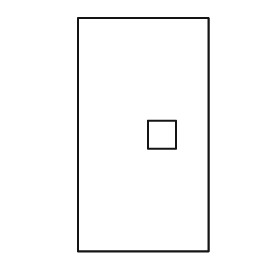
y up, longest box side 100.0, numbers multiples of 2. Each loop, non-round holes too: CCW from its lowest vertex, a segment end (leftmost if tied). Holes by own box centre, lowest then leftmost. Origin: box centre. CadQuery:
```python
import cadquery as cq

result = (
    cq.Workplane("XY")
    .moveTo(-28.0, -50.0)
    .lineTo(28.0, -50.0)
    .lineTo(28.0, 50.0)
    .lineTo(-28.0, 50.0)
    .close()
    .moveTo(2.0, -6.0)
    .lineTo(14.0, -6.0)
    .lineTo(14.0, 6.0)
    .lineTo(2.0, 6.0)
    .close()
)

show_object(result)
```